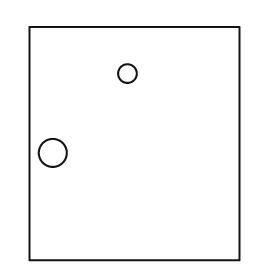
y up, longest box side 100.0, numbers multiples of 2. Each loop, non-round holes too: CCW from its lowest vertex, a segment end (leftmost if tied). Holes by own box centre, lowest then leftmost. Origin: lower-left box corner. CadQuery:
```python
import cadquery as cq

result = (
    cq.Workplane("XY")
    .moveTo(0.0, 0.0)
    .lineTo(90.0, 0.0)
    .lineTo(90.0, 100.0)
    .lineTo(0.0, 100.0)
    .close()
    .moveTo(10.0, 46.0)
    .circle(6.0)
    .moveTo(42.0, 80.0)
    .circle(4.0)
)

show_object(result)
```